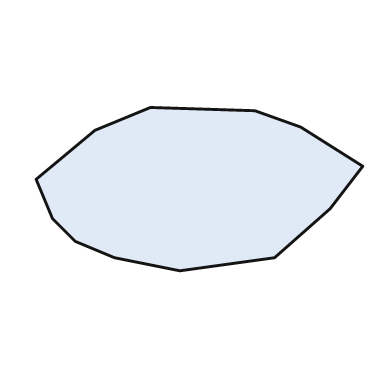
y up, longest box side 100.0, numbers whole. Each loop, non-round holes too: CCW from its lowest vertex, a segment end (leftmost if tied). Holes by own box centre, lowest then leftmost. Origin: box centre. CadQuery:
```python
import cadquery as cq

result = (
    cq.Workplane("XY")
    .moveTo(-6.0, -25.0)
    .lineTo(23.0, -21.0)
    .lineTo(40.0, -6.0)
    .lineTo(50.0, 7.0)
    .lineTo(31.0, 19.0)
    .lineTo(17.0, 24.0)
    .lineTo(-15.0, 25.0)
    .lineTo(-32.0, 18.0)
    .lineTo(-50.0, 3.0)
    .lineTo(-45.0, -9.0)
    .lineTo(-38.0, -16.0)
    .lineTo(-26.0, -21.0)
    .close()
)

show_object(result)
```